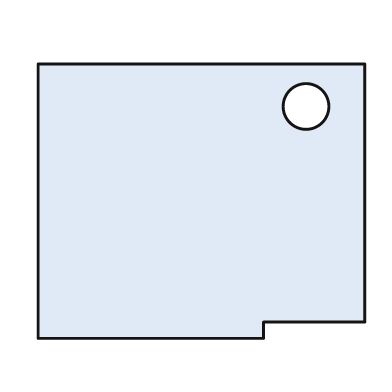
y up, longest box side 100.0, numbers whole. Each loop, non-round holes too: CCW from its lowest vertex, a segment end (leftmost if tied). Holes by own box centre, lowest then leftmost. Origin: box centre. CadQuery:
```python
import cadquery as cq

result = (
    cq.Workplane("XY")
    .moveTo(-50.0, -42.0)
    .lineTo(19.0, -42.0)
    .lineTo(19.0, -37.0)
    .lineTo(50.0, -37.0)
    .lineTo(50.0, 42.0)
    .lineTo(-50.0, 42.0)
    .close()
    .moveTo(32.0, 29.0)
    .circle(7.0)
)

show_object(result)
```